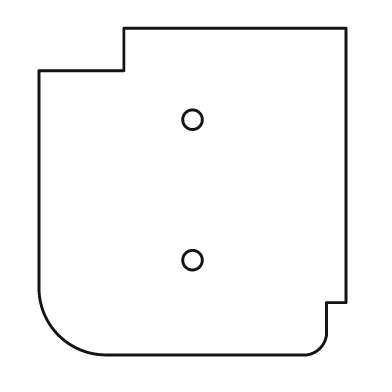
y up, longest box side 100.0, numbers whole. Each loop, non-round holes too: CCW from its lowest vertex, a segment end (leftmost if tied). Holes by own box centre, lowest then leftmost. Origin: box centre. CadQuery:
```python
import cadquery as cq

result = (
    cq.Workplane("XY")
    .moveTo(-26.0, -50.0)
    .lineTo(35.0, -50.0)
    .threePointArc((39.0, -48.0), (41.0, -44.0))
    .lineTo(41.0, -34.0)
    .lineTo(47.0, -34.0)
    .lineTo(47.0, 50.0)
    .lineTo(-21.0, 50.0)
    .lineTo(-21.0, 37.0)
    .lineTo(-47.0, 37.0)
    .lineTo(-47.0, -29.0)
    .threePointArc((-41.0, -44.0), (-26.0, -50.0))
    .close()
    .moveTo(0.0, -21.0)
    .circle(3.0)
    .moveTo(0.0, 22.0)
    .circle(3.0)
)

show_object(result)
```